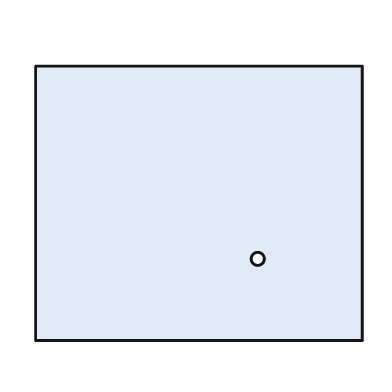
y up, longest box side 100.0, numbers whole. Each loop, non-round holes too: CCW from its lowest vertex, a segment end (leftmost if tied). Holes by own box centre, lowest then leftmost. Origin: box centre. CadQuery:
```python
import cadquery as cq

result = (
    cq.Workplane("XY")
    .moveTo(-50.0, -42.0)
    .lineTo(50.0, -42.0)
    .lineTo(50.0, 42.0)
    .lineTo(-50.0, 42.0)
    .close()
    .moveTo(18.0, -17.0)
    .circle(2.0)
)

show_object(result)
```